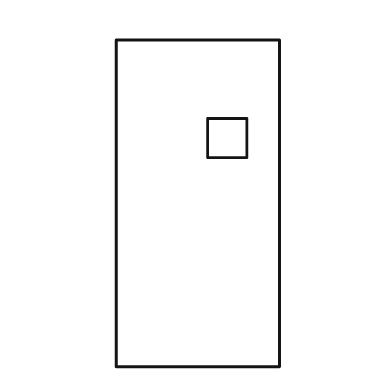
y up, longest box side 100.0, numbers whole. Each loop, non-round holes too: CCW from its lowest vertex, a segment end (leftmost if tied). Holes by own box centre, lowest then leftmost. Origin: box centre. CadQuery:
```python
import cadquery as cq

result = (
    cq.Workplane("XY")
    .moveTo(-25.0, -50.0)
    .lineTo(25.0, -50.0)
    .lineTo(25.0, 50.0)
    .lineTo(-25.0, 50.0)
    .close()
    .moveTo(3.0, 14.0)
    .lineTo(15.0, 14.0)
    .lineTo(15.0, 26.0)
    .lineTo(3.0, 26.0)
    .close()
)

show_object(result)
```